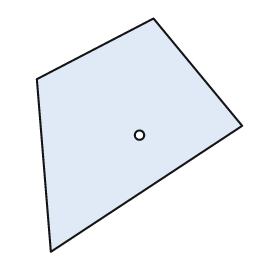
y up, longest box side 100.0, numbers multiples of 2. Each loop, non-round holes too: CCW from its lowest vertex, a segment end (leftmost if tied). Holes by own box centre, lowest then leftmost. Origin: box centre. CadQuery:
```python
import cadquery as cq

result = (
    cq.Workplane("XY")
    .moveTo(-38.0, -50.0)
    .lineTo(44.0, 4.0)
    .lineTo(6.0, 50.0)
    .lineTo(-44.0, 24.0)
    .close()
    .moveTo(0.0, 0.0)
    .circle(2.0)
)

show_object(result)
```